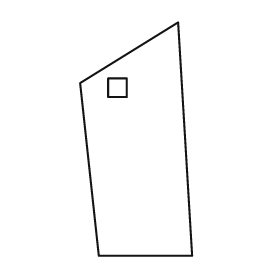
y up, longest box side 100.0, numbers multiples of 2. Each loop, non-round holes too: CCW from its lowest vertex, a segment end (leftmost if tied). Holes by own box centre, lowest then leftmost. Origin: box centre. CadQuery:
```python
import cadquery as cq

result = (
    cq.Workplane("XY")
    .moveTo(-16.0, -50.0)
    .lineTo(24.0, -50.0)
    .lineTo(18.0, 50.0)
    .lineTo(-24.0, 24.0)
    .close()
    .moveTo(-12.0, 18.0)
    .lineTo(-4.0, 18.0)
    .lineTo(-4.0, 26.0)
    .lineTo(-12.0, 26.0)
    .close()
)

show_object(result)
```